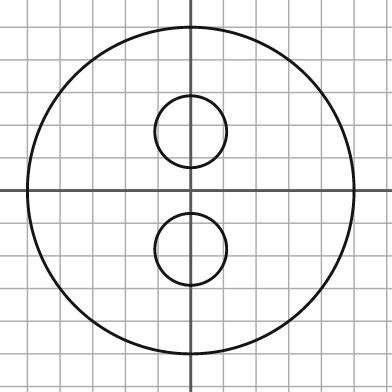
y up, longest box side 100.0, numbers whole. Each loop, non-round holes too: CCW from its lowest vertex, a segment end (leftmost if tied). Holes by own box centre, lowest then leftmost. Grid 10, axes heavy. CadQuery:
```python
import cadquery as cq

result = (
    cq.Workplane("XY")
    .moveTo(0.0, 0.0)
    .circle(50.0)
    .moveTo(0.0, -18.0)
    .circle(11.0)
    .moveTo(0.0, 18.0)
    .circle(11.0)
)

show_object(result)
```